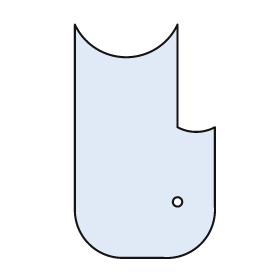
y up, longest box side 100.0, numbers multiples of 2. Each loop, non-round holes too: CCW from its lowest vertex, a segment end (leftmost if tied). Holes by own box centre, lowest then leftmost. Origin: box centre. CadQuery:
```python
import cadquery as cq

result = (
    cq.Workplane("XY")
    .moveTo(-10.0, -50.0)
    .lineTo(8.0, -50.0)
    .threePointArc((24.0, -44.0), (30.0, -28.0))
    .lineTo(30.0, 6.0)
    .threePointArc((22.0, 4.0), (14.0, 6.0))
    .lineTo(14.0, 50.0)
    .threePointArc((-8.0, 36.0), (-30.0, 50.0))
    .lineTo(-30.0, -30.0)
    .threePointArc((-24.0, -44.0), (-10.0, -50.0))
    .close()
    .moveTo(14.0, -26.0)
    .circle(2.0)
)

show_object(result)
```